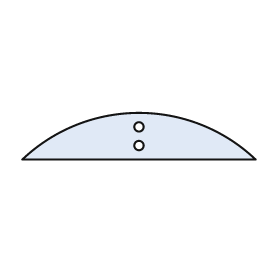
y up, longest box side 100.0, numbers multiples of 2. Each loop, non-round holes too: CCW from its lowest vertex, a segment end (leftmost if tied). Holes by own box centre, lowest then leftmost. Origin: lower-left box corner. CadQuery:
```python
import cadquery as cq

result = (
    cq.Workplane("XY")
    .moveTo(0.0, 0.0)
    .lineTo(100.0, 0.0)
    .threePointArc((50.0, 20.0), (0.0, 0.0))
    .close()
    .moveTo(50.0, 6.0)
    .circle(2.0)
    .moveTo(50.0, 14.0)
    .circle(2.0)
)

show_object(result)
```